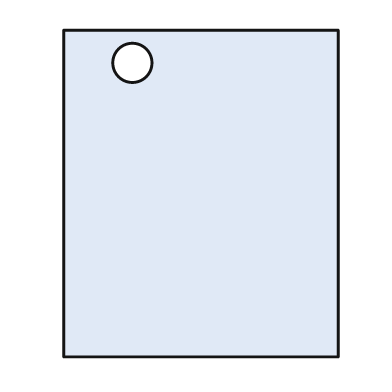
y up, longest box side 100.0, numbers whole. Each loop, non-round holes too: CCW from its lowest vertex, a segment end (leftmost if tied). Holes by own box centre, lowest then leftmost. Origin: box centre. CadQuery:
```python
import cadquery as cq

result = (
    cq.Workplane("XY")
    .moveTo(-42.0, -50.0)
    .lineTo(42.0, -50.0)
    .lineTo(42.0, 50.0)
    .lineTo(-42.0, 50.0)
    .close()
    .moveTo(-21.0, 40.0)
    .circle(6.0)
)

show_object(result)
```